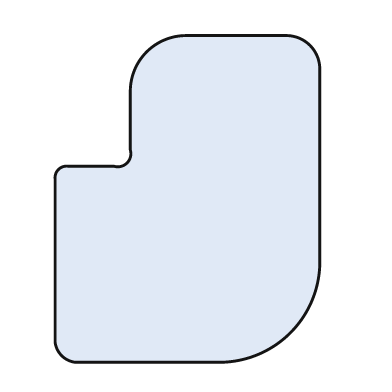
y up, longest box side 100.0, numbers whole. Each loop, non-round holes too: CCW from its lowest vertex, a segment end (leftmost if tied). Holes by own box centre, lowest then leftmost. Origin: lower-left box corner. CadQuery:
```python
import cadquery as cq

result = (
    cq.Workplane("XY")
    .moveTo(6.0, 0.0)
    .lineTo(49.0, 0.0)
    .threePointArc((72.0, 9.0), (81.0, 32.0))
    .lineTo(81.0, 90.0)
    .threePointArc((78.0, 97.0), (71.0, 100.0))
    .lineTo(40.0, 100.0)
    .threePointArc((28.0, 95.0), (23.0, 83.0))
    .lineTo(23.0, 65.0)
    .threePointArc((22.0, 61.0), (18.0, 60.0))
    .lineTo(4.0, 60.0)
    .threePointArc((1.0, 59.0), (0.0, 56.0))
    .lineTo(0.0, 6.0)
    .threePointArc((2.0, 2.0), (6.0, 0.0))
    .close()
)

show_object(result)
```